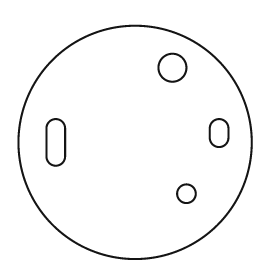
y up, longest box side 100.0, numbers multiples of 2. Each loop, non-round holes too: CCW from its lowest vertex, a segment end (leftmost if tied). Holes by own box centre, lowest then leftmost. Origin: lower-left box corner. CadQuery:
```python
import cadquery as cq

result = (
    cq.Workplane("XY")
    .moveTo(50.0, 50.0)
    .circle(50.0)
    .moveTo(72.0, 28.0)
    .circle(4.0)
    .moveTo(12.0, 44.0)
    .threePointArc((16.0, 40.0), (20.0, 44.0))
    .lineTo(20.0, 56.0)
    .threePointArc((16.0, 60.0), (12.0, 56.0))
    .close()
    .moveTo(82.0, 52.0)
    .threePointArc((86.0, 48.0), (90.0, 52.0))
    .lineTo(90.0, 56.0)
    .threePointArc((86.0, 60.0), (82.0, 56.0))
    .close()
    .moveTo(66.0, 82.0)
    .circle(6.0)
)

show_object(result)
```